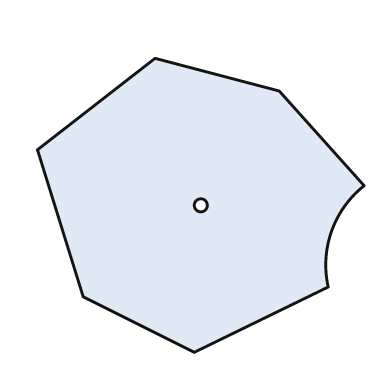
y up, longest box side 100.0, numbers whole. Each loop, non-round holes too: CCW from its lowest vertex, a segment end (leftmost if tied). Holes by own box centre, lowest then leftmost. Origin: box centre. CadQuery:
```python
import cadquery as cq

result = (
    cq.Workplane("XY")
    .moveTo(-2.0, -45.0)
    .lineTo(39.0, -25.0)
    .threePointArc((40.0, -8.0), (50.0, 6.0))
    .lineTo(24.0, 35.0)
    .lineTo(-14.0, 45.0)
    .lineTo(-50.0, 17.0)
    .lineTo(-36.0, -28.0)
    .close()
    .moveTo(0.0, 0.0)
    .circle(2.0)
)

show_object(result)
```